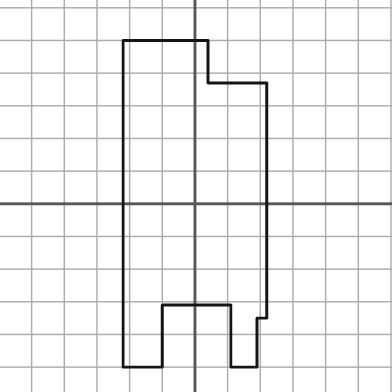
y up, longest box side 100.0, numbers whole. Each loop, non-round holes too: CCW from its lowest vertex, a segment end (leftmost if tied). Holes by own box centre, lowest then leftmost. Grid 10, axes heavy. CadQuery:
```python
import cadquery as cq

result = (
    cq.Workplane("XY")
    .moveTo(-22.0, -50.0)
    .lineTo(-10.0, -50.0)
    .lineTo(-10.0, -31.0)
    .lineTo(11.0, -31.0)
    .lineTo(11.0, -50.0)
    .lineTo(19.0, -50.0)
    .lineTo(19.0, -35.0)
    .lineTo(22.0, -35.0)
    .lineTo(22.0, 37.0)
    .lineTo(4.0, 37.0)
    .lineTo(4.0, 50.0)
    .lineTo(-22.0, 50.0)
    .close()
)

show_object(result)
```